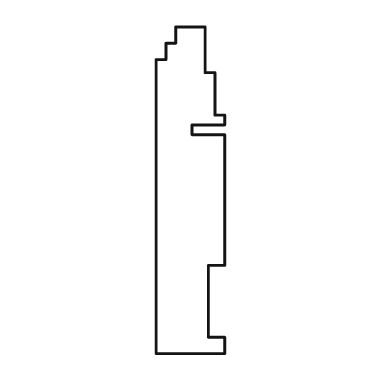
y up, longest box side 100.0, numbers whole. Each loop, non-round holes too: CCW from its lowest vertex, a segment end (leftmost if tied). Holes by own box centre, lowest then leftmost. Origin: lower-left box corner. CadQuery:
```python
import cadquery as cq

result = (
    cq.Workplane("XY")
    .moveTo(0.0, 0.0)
    .lineTo(21.0, 0.0)
    .lineTo(21.0, 5.0)
    .lineTo(16.0, 5.0)
    .lineTo(16.0, 27.0)
    .lineTo(21.0, 27.0)
    .lineTo(21.0, 67.0)
    .lineTo(11.0, 67.0)
    .lineTo(11.0, 70.0)
    .lineTo(21.0, 70.0)
    .lineTo(21.0, 73.0)
    .lineTo(18.0, 73.0)
    .lineTo(18.0, 86.0)
    .lineTo(15.0, 86.0)
    .lineTo(15.0, 100.0)
    .lineTo(6.0, 100.0)
    .lineTo(6.0, 95.0)
    .lineTo(3.0, 95.0)
    .lineTo(3.0, 90.0)
    .lineTo(0.0, 90.0)
    .close()
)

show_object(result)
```